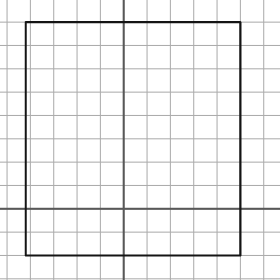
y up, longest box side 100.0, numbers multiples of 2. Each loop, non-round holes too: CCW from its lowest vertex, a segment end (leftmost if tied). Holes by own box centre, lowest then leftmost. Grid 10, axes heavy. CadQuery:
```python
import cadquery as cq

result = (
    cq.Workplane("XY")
    .moveTo(-42.0, -20.0)
    .lineTo(50.0, -20.0)
    .lineTo(50.0, 80.0)
    .lineTo(-42.0, 80.0)
    .close()
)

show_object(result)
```